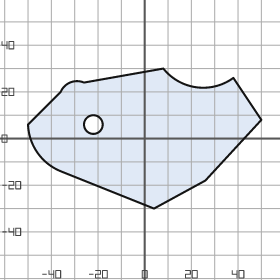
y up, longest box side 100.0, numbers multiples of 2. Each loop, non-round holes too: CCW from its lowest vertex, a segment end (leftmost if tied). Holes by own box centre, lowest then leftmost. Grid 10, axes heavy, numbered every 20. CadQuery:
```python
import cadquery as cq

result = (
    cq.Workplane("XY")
    .moveTo(4.0, -30.0)
    .lineTo(26.0, -18.0)
    .lineTo(50.0, 8.0)
    .lineTo(38.0, 26.0)
    .threePointArc((22.0, 22.0), (8.0, 30.0))
    .lineTo(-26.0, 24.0)
    .threePointArc((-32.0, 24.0), (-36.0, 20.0))
    .lineTo(-50.0, 6.0)
    .threePointArc((-46.0, -6.0), (-36.0, -14.0))
    .close()
    .moveTo(-22.0, 6.0)
    .circle(4.0)
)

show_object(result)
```